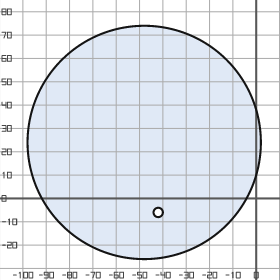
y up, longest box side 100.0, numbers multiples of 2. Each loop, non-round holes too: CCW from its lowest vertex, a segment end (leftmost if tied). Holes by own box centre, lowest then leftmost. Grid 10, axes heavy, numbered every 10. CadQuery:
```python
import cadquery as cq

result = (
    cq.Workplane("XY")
    .moveTo(-48.0, 24.0)
    .circle(50.0)
    .moveTo(-42.0, -6.0)
    .circle(2.0)
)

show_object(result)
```